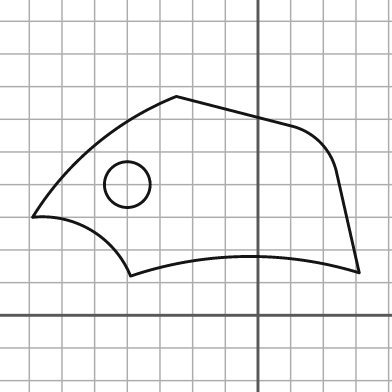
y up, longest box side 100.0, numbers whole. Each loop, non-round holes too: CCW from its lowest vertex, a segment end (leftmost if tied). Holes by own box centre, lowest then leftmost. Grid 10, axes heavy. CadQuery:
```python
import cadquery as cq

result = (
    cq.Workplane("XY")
    .moveTo(-39.0, 12.0)
    .threePointArc((-4.0, 18.0), (31.0, 13.0))
    .lineTo(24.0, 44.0)
    .threePointArc((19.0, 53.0), (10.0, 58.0))
    .lineTo(-25.0, 67.0)
    .threePointArc((-50.0, 52.0), (-69.0, 30.0))
    .threePointArc((-51.0, 26.0), (-39.0, 12.0))
    .close()
    .moveTo(-40.0, 40.0)
    .circle(7.0)
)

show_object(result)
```